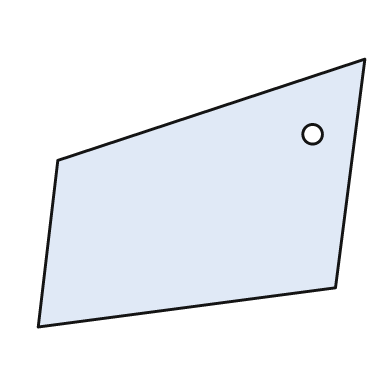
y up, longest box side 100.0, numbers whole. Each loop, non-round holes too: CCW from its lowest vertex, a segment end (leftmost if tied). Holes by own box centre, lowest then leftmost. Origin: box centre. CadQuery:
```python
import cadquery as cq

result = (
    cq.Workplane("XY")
    .moveTo(-50.0, -41.0)
    .lineTo(41.0, -29.0)
    .lineTo(50.0, 41.0)
    .lineTo(-44.0, 10.0)
    .close()
    .moveTo(34.0, 18.0)
    .circle(3.0)
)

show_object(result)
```